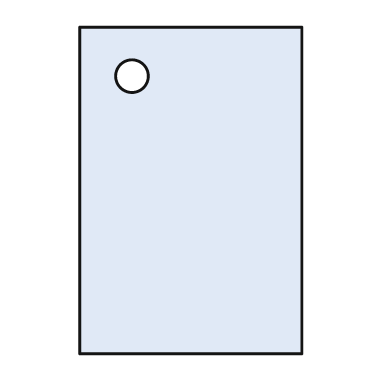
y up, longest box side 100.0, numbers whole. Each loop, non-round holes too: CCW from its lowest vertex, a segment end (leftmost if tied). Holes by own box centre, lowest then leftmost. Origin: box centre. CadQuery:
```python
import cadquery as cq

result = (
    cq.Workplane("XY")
    .moveTo(-34.0, -50.0)
    .lineTo(34.0, -50.0)
    .lineTo(34.0, 50.0)
    .lineTo(-34.0, 50.0)
    .close()
    .moveTo(-18.0, 35.0)
    .circle(5.0)
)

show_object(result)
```